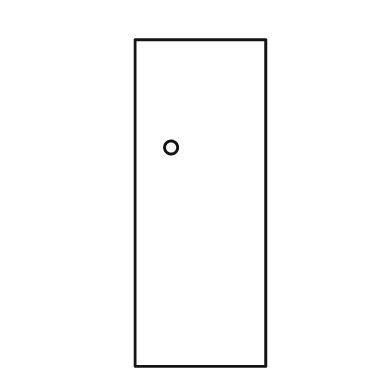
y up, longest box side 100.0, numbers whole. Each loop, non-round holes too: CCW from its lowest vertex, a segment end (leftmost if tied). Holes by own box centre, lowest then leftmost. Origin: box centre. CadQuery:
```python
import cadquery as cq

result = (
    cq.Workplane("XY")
    .moveTo(-20.0, -50.0)
    .lineTo(20.0, -50.0)
    .lineTo(20.0, 50.0)
    .lineTo(-20.0, 50.0)
    .close()
    .moveTo(-9.0, 17.0)
    .circle(2.0)
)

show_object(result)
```